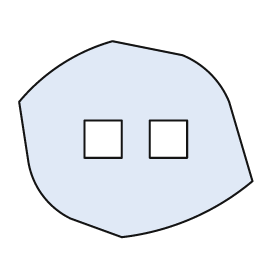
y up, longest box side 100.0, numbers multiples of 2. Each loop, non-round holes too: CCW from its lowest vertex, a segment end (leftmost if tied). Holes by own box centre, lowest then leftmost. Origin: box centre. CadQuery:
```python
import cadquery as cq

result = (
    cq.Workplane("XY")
    .moveTo(-6.0, -42.0)
    .threePointArc((24.0, -34.0), (50.0, -18.0))
    .lineTo(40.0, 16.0)
    .threePointArc((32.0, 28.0), (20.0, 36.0))
    .lineTo(-10.0, 42.0)
    .threePointArc((-32.0, 32.0), (-50.0, 16.0))
    .lineTo(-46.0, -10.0)
    .threePointArc((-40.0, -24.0), (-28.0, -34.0))
    .close()
    .moveTo(-22.0, -8.0)
    .lineTo(-6.0, -8.0)
    .lineTo(-6.0, 8.0)
    .lineTo(-22.0, 8.0)
    .close()
    .moveTo(6.0, -8.0)
    .lineTo(22.0, -8.0)
    .lineTo(22.0, 8.0)
    .lineTo(6.0, 8.0)
    .close()
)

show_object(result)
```